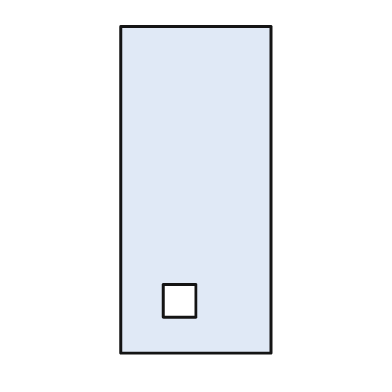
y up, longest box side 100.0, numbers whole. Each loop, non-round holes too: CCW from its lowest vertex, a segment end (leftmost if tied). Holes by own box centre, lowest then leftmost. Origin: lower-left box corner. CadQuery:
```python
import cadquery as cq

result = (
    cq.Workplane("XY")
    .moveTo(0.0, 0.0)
    .lineTo(46.0, 0.0)
    .lineTo(46.0, 100.0)
    .lineTo(0.0, 100.0)
    .close()
    .moveTo(13.0, 11.0)
    .lineTo(23.0, 11.0)
    .lineTo(23.0, 21.0)
    .lineTo(13.0, 21.0)
    .close()
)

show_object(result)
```